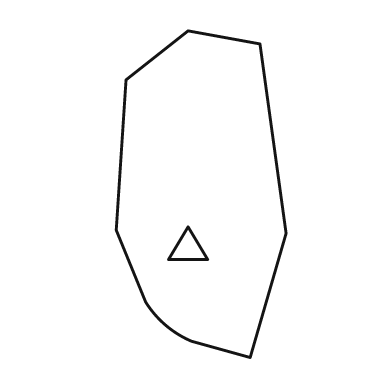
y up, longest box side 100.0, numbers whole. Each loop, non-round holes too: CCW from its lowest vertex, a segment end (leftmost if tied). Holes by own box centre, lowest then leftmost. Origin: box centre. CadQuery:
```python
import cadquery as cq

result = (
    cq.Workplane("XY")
    .moveTo(15.0, -50.0)
    .lineTo(26.0, -12.0)
    .lineTo(18.0, 46.0)
    .lineTo(-4.0, 50.0)
    .lineTo(-23.0, 35.0)
    .lineTo(-26.0, -11.0)
    .lineTo(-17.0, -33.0)
    .threePointArc((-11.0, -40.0), (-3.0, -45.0))
    .close()
    .moveTo(-10.0, -20.0)
    .lineTo(2.0, -20.0)
    .lineTo(-4.0, -10.0)
    .close()
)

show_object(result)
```